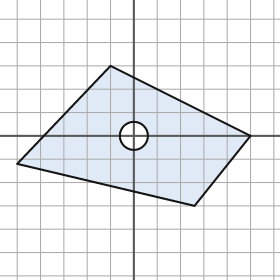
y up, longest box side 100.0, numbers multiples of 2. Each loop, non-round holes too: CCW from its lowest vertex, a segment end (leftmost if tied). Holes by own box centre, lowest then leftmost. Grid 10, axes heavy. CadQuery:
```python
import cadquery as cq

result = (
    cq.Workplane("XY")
    .moveTo(26.0, -30.0)
    .lineTo(50.0, 0.0)
    .lineTo(-10.0, 30.0)
    .lineTo(-50.0, -12.0)
    .close()
    .moveTo(0.0, 0.0)
    .circle(6.0)
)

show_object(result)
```